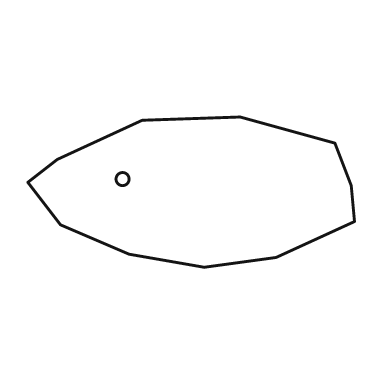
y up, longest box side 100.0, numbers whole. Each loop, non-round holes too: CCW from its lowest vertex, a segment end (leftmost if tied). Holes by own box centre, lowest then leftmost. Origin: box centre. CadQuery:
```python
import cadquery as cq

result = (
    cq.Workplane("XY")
    .moveTo(4.0, -23.0)
    .lineTo(26.0, -20.0)
    .lineTo(50.0, -9.0)
    .lineTo(49.0, 2.0)
    .lineTo(44.0, 15.0)
    .lineTo(15.0, 23.0)
    .lineTo(-15.0, 22.0)
    .lineTo(-41.0, 10.0)
    .lineTo(-50.0, 3.0)
    .lineTo(-40.0, -10.0)
    .lineTo(-19.0, -19.0)
    .close()
    .moveTo(-21.0, 4.0)
    .circle(2.0)
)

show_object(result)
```